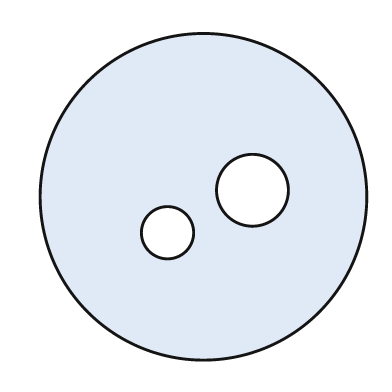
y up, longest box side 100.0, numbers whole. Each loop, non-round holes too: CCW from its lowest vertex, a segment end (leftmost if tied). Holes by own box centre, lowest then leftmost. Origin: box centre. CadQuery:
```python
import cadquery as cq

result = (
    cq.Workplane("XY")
    .moveTo(0.0, 0.0)
    .circle(50.0)
    .moveTo(-11.0, -11.0)
    .circle(8.0)
    .moveTo(15.0, 2.0)
    .circle(11.0)
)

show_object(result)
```